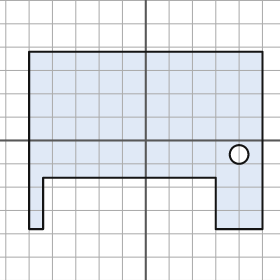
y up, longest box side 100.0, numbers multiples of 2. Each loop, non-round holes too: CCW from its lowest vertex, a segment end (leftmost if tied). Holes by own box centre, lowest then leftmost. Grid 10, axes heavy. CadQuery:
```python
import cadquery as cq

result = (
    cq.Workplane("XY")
    .moveTo(-50.0, -38.0)
    .lineTo(-44.0, -38.0)
    .lineTo(-44.0, -16.0)
    .lineTo(30.0, -16.0)
    .lineTo(30.0, -38.0)
    .lineTo(50.0, -38.0)
    .lineTo(50.0, 38.0)
    .lineTo(-50.0, 38.0)
    .close()
    .moveTo(40.0, -6.0)
    .circle(4.0)
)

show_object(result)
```